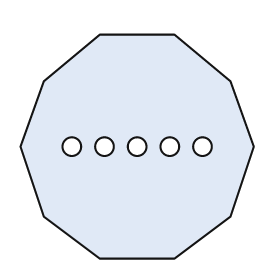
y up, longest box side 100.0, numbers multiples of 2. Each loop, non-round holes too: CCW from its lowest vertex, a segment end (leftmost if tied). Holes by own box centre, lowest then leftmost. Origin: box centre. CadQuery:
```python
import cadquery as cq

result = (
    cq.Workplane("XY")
    .moveTo(-16.0, -48.0)
    .lineTo(16.0, -48.0)
    .lineTo(40.0, -30.0)
    .lineTo(50.0, 0.0)
    .lineTo(40.0, 28.0)
    .lineTo(16.0, 48.0)
    .lineTo(-16.0, 48.0)
    .lineTo(-40.0, 28.0)
    .lineTo(-50.0, 0.0)
    .lineTo(-40.0, -30.0)
    .close()
    .moveTo(-28.0, 0.0)
    .circle(4.0)
    .moveTo(-14.0, 0.0)
    .circle(4.0)
    .moveTo(0.0, 0.0)
    .circle(4.0)
    .moveTo(14.0, 0.0)
    .circle(4.0)
    .moveTo(28.0, 0.0)
    .circle(4.0)
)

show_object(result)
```